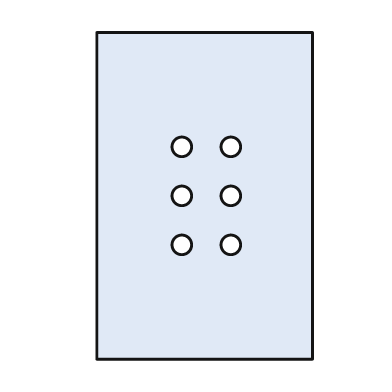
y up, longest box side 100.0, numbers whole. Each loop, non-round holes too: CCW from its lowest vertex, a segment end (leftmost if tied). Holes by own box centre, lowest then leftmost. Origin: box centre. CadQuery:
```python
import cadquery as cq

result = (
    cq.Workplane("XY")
    .moveTo(-33.0, -50.0)
    .lineTo(33.0, -50.0)
    .lineTo(33.0, 50.0)
    .lineTo(-33.0, 50.0)
    .close()
    .moveTo(-7.0, -15.0)
    .circle(3.0)
    .moveTo(8.0, -15.0)
    .circle(3.0)
    .moveTo(-7.0, 0.0)
    .circle(3.0)
    .moveTo(8.0, 0.0)
    .circle(3.0)
    .moveTo(-7.0, 15.0)
    .circle(3.0)
    .moveTo(8.0, 15.0)
    .circle(3.0)
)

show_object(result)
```